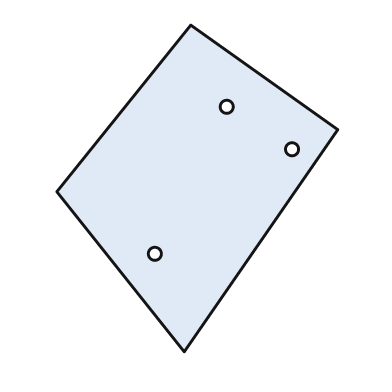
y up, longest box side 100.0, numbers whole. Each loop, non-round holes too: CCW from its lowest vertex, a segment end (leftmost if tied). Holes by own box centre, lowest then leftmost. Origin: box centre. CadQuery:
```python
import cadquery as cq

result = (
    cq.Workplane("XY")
    .moveTo(-4.0, -50.0)
    .lineTo(43.0, 18.0)
    .lineTo(-2.0, 50.0)
    .lineTo(-43.0, -1.0)
    .close()
    .moveTo(-13.0, -20.0)
    .circle(2.0)
    .moveTo(29.0, 12.0)
    .circle(2.0)
    .moveTo(9.0, 25.0)
    .circle(2.0)
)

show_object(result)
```